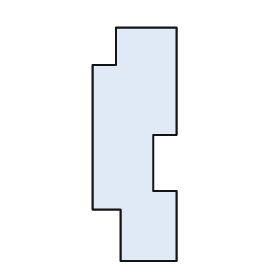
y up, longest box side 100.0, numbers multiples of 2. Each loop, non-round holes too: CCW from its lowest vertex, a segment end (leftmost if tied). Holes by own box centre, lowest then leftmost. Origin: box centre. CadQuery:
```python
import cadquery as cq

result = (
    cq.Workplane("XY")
    .moveTo(-6.0, -50.0)
    .lineTo(18.0, -50.0)
    .lineTo(18.0, -20.0)
    .lineTo(8.0, -20.0)
    .lineTo(8.0, 4.0)
    .lineTo(18.0, 4.0)
    .lineTo(18.0, 50.0)
    .lineTo(-8.0, 50.0)
    .lineTo(-8.0, 34.0)
    .lineTo(-18.0, 34.0)
    .lineTo(-18.0, -28.0)
    .lineTo(-6.0, -28.0)
    .close()
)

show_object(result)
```